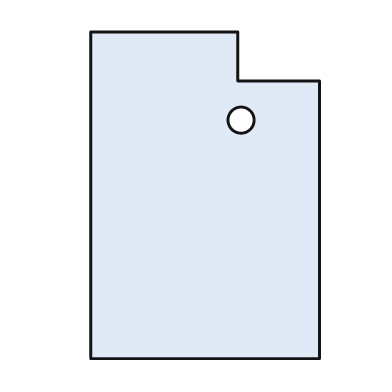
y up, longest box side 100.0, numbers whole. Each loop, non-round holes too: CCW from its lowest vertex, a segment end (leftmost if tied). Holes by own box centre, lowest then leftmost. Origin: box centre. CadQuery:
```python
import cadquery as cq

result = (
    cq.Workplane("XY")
    .moveTo(-35.0, -50.0)
    .lineTo(35.0, -50.0)
    .lineTo(35.0, 35.0)
    .lineTo(10.0, 35.0)
    .lineTo(10.0, 50.0)
    .lineTo(-35.0, 50.0)
    .close()
    .moveTo(11.0, 23.0)
    .circle(4.0)
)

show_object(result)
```